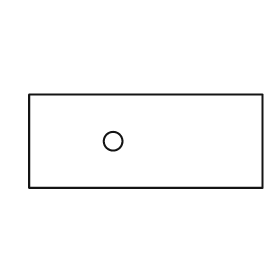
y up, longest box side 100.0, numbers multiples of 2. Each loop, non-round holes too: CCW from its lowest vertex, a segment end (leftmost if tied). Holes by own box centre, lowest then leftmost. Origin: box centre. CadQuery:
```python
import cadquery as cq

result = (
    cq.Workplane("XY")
    .moveTo(-50.0, -20.0)
    .lineTo(50.0, -20.0)
    .lineTo(50.0, 20.0)
    .lineTo(-50.0, 20.0)
    .close()
    .moveTo(-14.0, 0.0)
    .circle(4.0)
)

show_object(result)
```